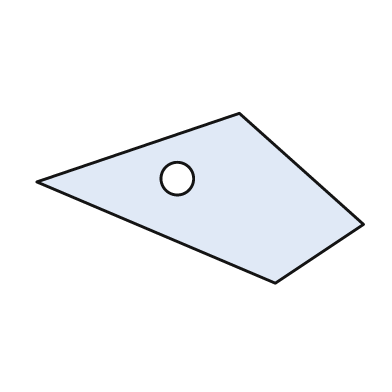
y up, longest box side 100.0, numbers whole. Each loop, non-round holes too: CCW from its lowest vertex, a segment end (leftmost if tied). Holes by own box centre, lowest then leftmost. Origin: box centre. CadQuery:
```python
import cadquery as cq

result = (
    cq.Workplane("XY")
    .moveTo(23.0, -26.0)
    .lineTo(50.0, -8.0)
    .lineTo(12.0, 26.0)
    .lineTo(-50.0, 5.0)
    .close()
    .moveTo(-7.0, 6.0)
    .circle(5.0)
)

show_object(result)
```